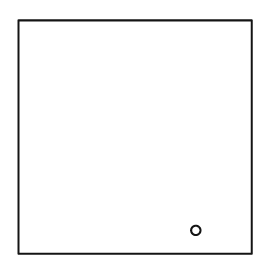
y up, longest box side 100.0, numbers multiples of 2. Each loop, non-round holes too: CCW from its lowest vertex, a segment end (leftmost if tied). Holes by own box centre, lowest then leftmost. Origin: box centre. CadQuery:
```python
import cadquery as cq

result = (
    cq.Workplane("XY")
    .moveTo(-50.0, -50.0)
    .lineTo(50.0, -50.0)
    .lineTo(50.0, 50.0)
    .lineTo(-50.0, 50.0)
    .close()
    .moveTo(26.0, -40.0)
    .circle(2.0)
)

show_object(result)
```